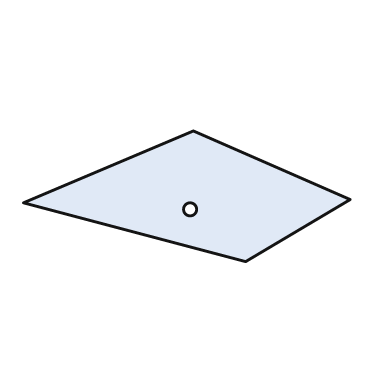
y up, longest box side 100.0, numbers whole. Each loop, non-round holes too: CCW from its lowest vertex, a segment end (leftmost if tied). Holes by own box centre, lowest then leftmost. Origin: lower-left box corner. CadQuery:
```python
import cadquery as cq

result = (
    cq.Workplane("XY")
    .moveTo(68.0, 0.0)
    .lineTo(100.0, 19.0)
    .lineTo(52.0, 40.0)
    .lineTo(0.0, 18.0)
    .close()
    .moveTo(51.0, 16.0)
    .circle(2.0)
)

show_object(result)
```